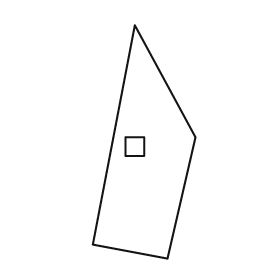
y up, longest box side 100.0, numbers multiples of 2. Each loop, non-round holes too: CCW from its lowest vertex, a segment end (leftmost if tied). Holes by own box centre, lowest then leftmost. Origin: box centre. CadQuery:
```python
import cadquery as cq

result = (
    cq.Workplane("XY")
    .moveTo(10.0, -50.0)
    .lineTo(22.0, 2.0)
    .lineTo(-4.0, 50.0)
    .lineTo(-22.0, -44.0)
    .close()
    .moveTo(-8.0, -6.0)
    .lineTo(0.0, -6.0)
    .lineTo(0.0, 2.0)
    .lineTo(-8.0, 2.0)
    .close()
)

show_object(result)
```